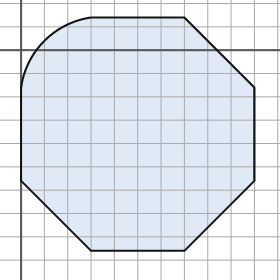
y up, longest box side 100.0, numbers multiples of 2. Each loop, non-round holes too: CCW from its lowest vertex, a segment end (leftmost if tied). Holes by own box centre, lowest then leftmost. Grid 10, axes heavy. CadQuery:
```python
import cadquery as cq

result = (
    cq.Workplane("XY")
    .moveTo(30.0, -86.0)
    .lineTo(70.0, -86.0)
    .lineTo(100.0, -56.0)
    .lineTo(100.0, -16.0)
    .lineTo(70.0, 14.0)
    .lineTo(30.0, 14.0)
    .threePointArc((10.0, 4.0), (0.0, -16.0))
    .lineTo(0.0, -56.0)
    .close()
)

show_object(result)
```